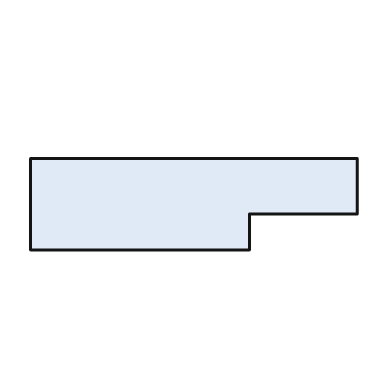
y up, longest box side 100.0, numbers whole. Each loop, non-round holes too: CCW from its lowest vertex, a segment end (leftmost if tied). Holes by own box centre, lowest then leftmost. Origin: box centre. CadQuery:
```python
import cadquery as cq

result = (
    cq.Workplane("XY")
    .moveTo(-50.0, -14.0)
    .lineTo(17.0, -14.0)
    .lineTo(17.0, -3.0)
    .lineTo(50.0, -3.0)
    .lineTo(50.0, 14.0)
    .lineTo(-50.0, 14.0)
    .close()
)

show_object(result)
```